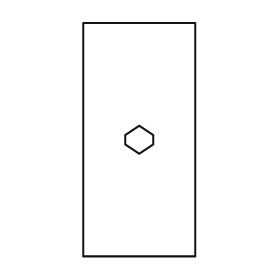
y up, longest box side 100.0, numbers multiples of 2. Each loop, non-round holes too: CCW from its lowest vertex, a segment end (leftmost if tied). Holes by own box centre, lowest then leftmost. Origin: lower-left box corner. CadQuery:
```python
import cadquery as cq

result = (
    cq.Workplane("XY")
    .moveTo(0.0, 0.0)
    .lineTo(48.0, 0.0)
    .lineTo(48.0, 100.0)
    .lineTo(0.0, 100.0)
    .close()
    .moveTo(24.0, 44.0)
    .lineTo(30.0, 48.0)
    .lineTo(30.0, 52.0)
    .lineTo(24.0, 56.0)
    .lineTo(18.0, 52.0)
    .lineTo(18.0, 48.0)
    .close()
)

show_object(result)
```